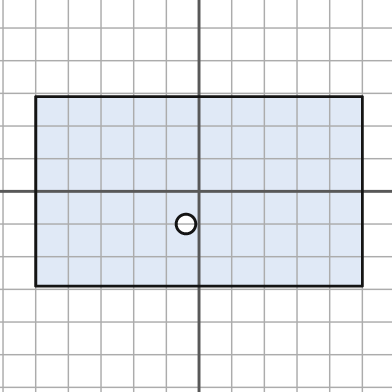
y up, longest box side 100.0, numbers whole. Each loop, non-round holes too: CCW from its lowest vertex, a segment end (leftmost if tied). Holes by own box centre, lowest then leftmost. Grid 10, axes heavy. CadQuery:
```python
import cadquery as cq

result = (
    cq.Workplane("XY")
    .moveTo(-50.0, -29.0)
    .lineTo(50.0, -29.0)
    .lineTo(50.0, 29.0)
    .lineTo(-50.0, 29.0)
    .close()
    .moveTo(-4.0, -10.0)
    .circle(3.0)
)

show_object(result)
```